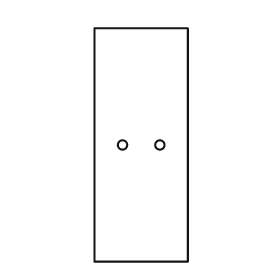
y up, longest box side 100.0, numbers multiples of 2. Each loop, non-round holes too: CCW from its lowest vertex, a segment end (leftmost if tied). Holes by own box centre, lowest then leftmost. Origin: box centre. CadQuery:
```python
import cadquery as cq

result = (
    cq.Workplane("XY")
    .moveTo(-20.0, -50.0)
    .lineTo(20.0, -50.0)
    .lineTo(20.0, 50.0)
    .lineTo(-20.0, 50.0)
    .close()
    .moveTo(-8.0, 0.0)
    .circle(2.0)
    .moveTo(8.0, 0.0)
    .circle(2.0)
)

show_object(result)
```